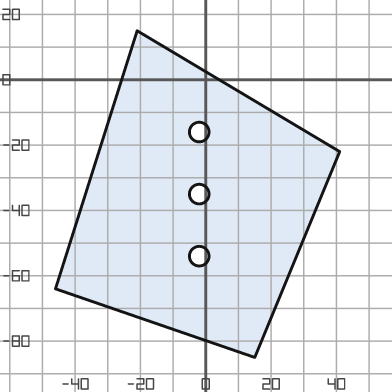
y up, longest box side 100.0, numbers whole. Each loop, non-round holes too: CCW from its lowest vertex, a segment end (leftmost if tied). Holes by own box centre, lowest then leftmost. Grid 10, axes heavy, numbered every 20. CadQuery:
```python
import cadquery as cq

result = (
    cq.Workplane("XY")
    .moveTo(15.0, -85.0)
    .lineTo(41.0, -22.0)
    .lineTo(-21.0, 15.0)
    .lineTo(-46.0, -64.0)
    .close()
    .moveTo(-2.0, -54.0)
    .circle(3.0)
    .moveTo(-2.0, -35.0)
    .circle(3.0)
    .moveTo(-2.0, -16.0)
    .circle(3.0)
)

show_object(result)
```